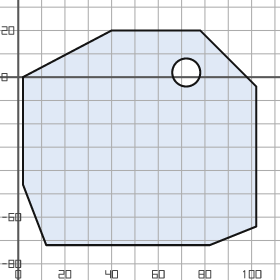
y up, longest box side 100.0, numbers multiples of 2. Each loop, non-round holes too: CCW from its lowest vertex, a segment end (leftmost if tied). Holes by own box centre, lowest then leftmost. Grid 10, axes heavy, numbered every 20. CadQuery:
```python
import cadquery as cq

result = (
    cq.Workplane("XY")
    .moveTo(12.0, -72.0)
    .lineTo(82.0, -72.0)
    .lineTo(102.0, -64.0)
    .lineTo(102.0, -4.0)
    .lineTo(78.0, 20.0)
    .lineTo(40.0, 20.0)
    .lineTo(2.0, 0.0)
    .lineTo(2.0, -46.0)
    .close()
    .moveTo(72.0, 2.0)
    .circle(6.0)
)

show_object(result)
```